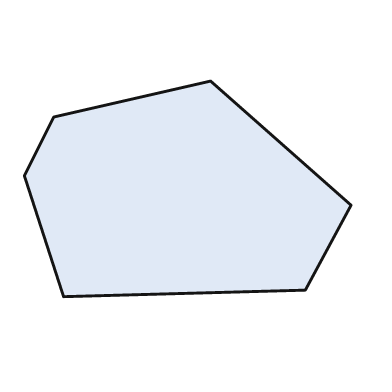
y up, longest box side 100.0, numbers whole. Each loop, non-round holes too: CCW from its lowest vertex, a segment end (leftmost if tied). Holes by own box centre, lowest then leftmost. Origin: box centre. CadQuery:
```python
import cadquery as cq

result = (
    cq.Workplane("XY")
    .moveTo(-38.0, -33.0)
    .lineTo(36.0, -31.0)
    .lineTo(50.0, -5.0)
    .lineTo(7.0, 33.0)
    .lineTo(-41.0, 22.0)
    .lineTo(-50.0, 4.0)
    .close()
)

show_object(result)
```